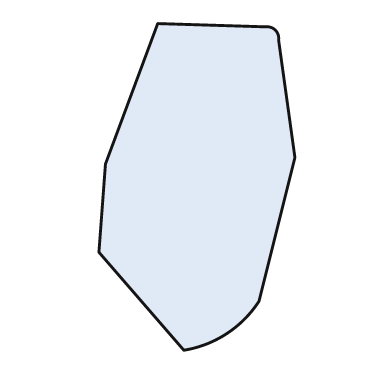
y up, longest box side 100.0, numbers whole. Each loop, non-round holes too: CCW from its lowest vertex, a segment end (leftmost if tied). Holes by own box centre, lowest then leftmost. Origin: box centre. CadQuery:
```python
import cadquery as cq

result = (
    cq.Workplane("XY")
    .moveTo(-4.0, -50.0)
    .threePointArc((9.0, -45.0), (19.0, -35.0))
    .lineTo(30.0, 9.0)
    .lineTo(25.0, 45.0)
    .threePointArc((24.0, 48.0), (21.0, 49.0))
    .lineTo(-12.0, 50.0)
    .lineTo(-28.0, 7.0)
    .lineTo(-30.0, -20.0)
    .close()
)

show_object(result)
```